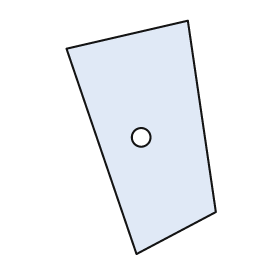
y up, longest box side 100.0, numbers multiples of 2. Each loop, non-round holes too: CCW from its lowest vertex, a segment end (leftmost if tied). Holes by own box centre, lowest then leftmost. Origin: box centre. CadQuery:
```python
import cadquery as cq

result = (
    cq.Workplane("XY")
    .moveTo(-2.0, -50.0)
    .lineTo(32.0, -32.0)
    .lineTo(20.0, 50.0)
    .lineTo(-32.0, 38.0)
    .close()
    .moveTo(0.0, 0.0)
    .circle(4.0)
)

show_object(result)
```